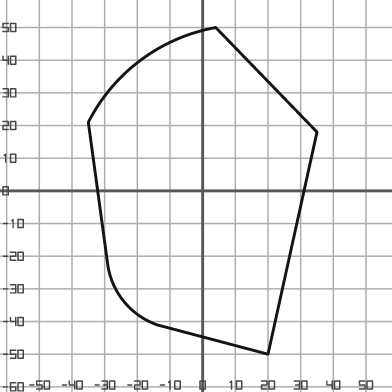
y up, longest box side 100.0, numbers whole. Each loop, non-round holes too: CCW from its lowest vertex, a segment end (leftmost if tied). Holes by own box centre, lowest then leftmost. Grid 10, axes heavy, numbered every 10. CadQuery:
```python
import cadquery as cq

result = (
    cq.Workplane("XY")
    .moveTo(20.0, -50.0)
    .lineTo(35.0, 18.0)
    .lineTo(4.0, 50.0)
    .threePointArc((-19.0, 40.0), (-35.0, 21.0))
    .lineTo(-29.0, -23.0)
    .threePointArc((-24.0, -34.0), (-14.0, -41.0))
    .close()
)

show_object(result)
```